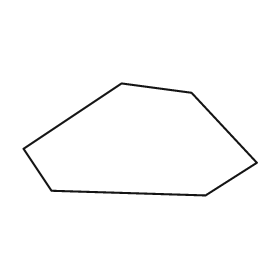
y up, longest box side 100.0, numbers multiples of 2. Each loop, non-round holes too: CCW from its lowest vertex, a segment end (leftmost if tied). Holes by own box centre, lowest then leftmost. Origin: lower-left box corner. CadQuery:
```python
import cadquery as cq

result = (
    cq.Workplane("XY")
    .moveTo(78.0, 0.0)
    .lineTo(100.0, 14.0)
    .lineTo(72.0, 44.0)
    .lineTo(42.0, 48.0)
    .lineTo(0.0, 20.0)
    .lineTo(12.0, 2.0)
    .close()
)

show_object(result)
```